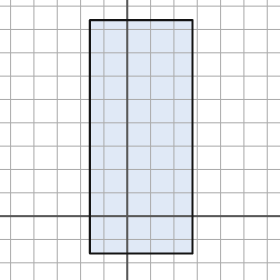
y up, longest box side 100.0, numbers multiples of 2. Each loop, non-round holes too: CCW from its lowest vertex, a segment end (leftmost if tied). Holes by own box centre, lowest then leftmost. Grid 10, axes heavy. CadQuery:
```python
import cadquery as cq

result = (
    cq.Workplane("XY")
    .moveTo(-16.0, -16.0)
    .lineTo(28.0, -16.0)
    .lineTo(28.0, 84.0)
    .lineTo(-16.0, 84.0)
    .close()
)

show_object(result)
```